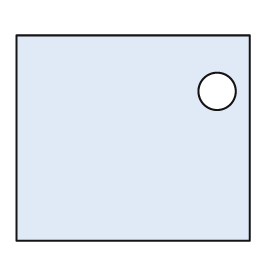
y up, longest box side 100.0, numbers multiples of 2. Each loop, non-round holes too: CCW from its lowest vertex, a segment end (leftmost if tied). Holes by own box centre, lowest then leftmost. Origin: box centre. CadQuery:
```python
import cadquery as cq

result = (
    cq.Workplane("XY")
    .moveTo(-50.0, -44.0)
    .lineTo(50.0, -44.0)
    .lineTo(50.0, 44.0)
    .lineTo(-50.0, 44.0)
    .close()
    .moveTo(36.0, 20.0)
    .circle(8.0)
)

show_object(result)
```